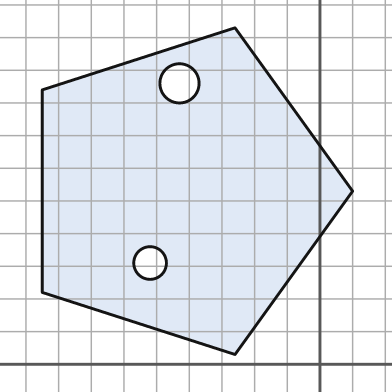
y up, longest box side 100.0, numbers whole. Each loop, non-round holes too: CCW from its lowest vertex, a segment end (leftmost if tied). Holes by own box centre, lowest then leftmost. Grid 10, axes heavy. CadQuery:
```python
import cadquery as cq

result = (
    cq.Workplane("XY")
    .moveTo(-26.0, 3.0)
    .lineTo(10.0, 53.0)
    .lineTo(-26.0, 103.0)
    .lineTo(-85.0, 84.0)
    .lineTo(-85.0, 22.0)
    .close()
    .moveTo(-52.0, 31.0)
    .circle(5.0)
    .moveTo(-43.0, 86.0)
    .circle(6.0)
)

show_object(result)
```